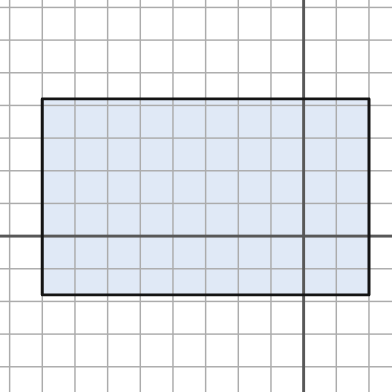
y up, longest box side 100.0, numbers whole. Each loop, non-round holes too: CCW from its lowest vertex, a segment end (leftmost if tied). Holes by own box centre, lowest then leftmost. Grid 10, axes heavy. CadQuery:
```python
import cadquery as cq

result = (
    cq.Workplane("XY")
    .moveTo(-80.0, -18.0)
    .lineTo(20.0, -18.0)
    .lineTo(20.0, 42.0)
    .lineTo(-80.0, 42.0)
    .close()
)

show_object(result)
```